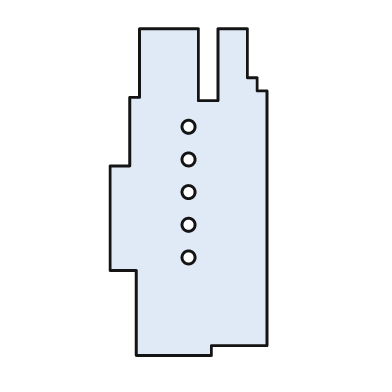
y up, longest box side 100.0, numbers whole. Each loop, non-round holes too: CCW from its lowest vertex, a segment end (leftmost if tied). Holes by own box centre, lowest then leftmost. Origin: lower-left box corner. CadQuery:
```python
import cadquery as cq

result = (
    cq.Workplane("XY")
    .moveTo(8.0, 0.0)
    .lineTo(31.0, 0.0)
    .lineTo(31.0, 3.0)
    .lineTo(48.0, 3.0)
    .lineTo(48.0, 81.0)
    .lineTo(45.0, 81.0)
    .lineTo(45.0, 85.0)
    .lineTo(42.0, 85.0)
    .lineTo(42.0, 100.0)
    .lineTo(33.0, 100.0)
    .lineTo(33.0, 78.0)
    .lineTo(27.0, 78.0)
    .lineTo(27.0, 100.0)
    .lineTo(9.0, 100.0)
    .lineTo(9.0, 79.0)
    .lineTo(6.0, 79.0)
    .lineTo(6.0, 58.0)
    .lineTo(0.0, 58.0)
    .lineTo(0.0, 26.0)
    .lineTo(8.0, 26.0)
    .close()
    .moveTo(24.0, 30.0)
    .circle(2.0)
    .moveTo(24.0, 40.0)
    .circle(2.0)
    .moveTo(24.0, 50.0)
    .circle(2.0)
    .moveTo(24.0, 60.0)
    .circle(2.0)
    .moveTo(24.0, 70.0)
    .circle(2.0)
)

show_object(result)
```